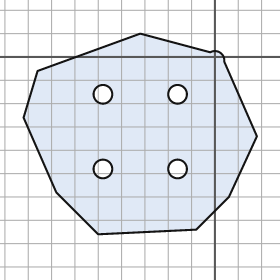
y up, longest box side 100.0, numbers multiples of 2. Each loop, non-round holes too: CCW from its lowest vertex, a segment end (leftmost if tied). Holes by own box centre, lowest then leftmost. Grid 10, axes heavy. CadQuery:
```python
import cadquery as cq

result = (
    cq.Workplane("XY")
    .moveTo(-50.0, -76.0)
    .lineTo(-8.0, -74.0)
    .lineTo(6.0, -60.0)
    .lineTo(18.0, -34.0)
    .lineTo(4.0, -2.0)
    .threePointArc((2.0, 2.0), (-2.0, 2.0))
    .lineTo(-32.0, 10.0)
    .lineTo(-76.0, -6.0)
    .lineTo(-82.0, -26.0)
    .lineTo(-68.0, -58.0)
    .close()
    .moveTo(-48.0, -48.0)
    .circle(4.0)
    .moveTo(-16.0, -48.0)
    .circle(4.0)
    .moveTo(-48.0, -16.0)
    .circle(4.0)
    .moveTo(-16.0, -16.0)
    .circle(4.0)
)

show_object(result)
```